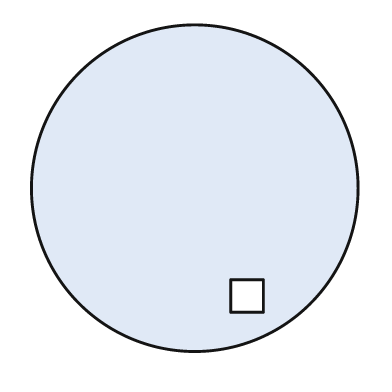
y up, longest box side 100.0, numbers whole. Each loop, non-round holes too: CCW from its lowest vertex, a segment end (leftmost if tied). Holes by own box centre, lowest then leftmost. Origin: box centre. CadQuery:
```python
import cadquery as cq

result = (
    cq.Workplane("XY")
    .moveTo(0.0, 0.0)
    .circle(50.0)
    .moveTo(11.0, -38.0)
    .lineTo(21.0, -38.0)
    .lineTo(21.0, -28.0)
    .lineTo(11.0, -28.0)
    .close()
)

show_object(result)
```